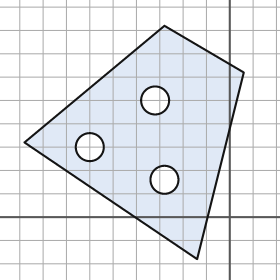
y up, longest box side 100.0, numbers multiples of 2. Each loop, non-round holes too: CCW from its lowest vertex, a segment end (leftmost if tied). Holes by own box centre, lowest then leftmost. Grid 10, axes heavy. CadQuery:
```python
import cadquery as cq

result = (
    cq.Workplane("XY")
    .moveTo(-14.0, -18.0)
    .lineTo(6.0, 62.0)
    .lineTo(-28.0, 82.0)
    .lineTo(-88.0, 32.0)
    .close()
    .moveTo(-28.0, 16.0)
    .circle(6.0)
    .moveTo(-60.0, 30.0)
    .circle(6.0)
    .moveTo(-32.0, 50.0)
    .circle(6.0)
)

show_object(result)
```